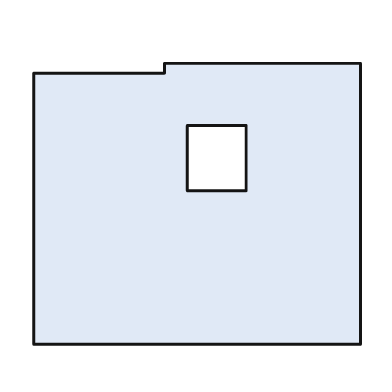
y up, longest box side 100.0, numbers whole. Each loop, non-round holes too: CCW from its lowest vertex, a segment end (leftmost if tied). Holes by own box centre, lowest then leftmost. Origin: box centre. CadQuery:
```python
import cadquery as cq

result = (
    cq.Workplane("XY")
    .moveTo(-50.0, -43.0)
    .lineTo(50.0, -43.0)
    .lineTo(50.0, 43.0)
    .lineTo(-10.0, 43.0)
    .lineTo(-10.0, 40.0)
    .lineTo(-50.0, 40.0)
    .close()
    .moveTo(-3.0, 4.0)
    .lineTo(15.0, 4.0)
    .lineTo(15.0, 24.0)
    .lineTo(-3.0, 24.0)
    .close()
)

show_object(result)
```